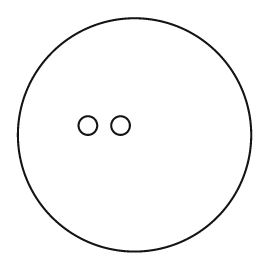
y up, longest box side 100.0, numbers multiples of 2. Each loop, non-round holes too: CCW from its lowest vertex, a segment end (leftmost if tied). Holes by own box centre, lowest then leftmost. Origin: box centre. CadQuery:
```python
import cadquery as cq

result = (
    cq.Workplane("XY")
    .moveTo(0.0, 0.0)
    .circle(50.0)
    .moveTo(-20.0, 4.0)
    .circle(4.0)
    .moveTo(-6.0, 4.0)
    .circle(4.0)
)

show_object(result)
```